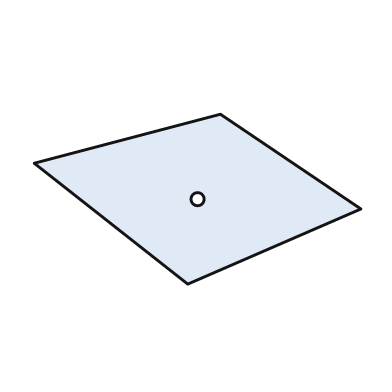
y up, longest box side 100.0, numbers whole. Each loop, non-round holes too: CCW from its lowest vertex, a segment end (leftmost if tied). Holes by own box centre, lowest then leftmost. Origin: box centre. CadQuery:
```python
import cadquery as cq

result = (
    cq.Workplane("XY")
    .moveTo(-3.0, -26.0)
    .lineTo(50.0, -3.0)
    .lineTo(7.0, 26.0)
    .lineTo(-50.0, 11.0)
    .close()
    .moveTo(0.0, 0.0)
    .circle(2.0)
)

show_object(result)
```